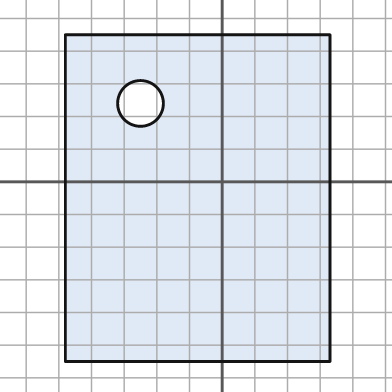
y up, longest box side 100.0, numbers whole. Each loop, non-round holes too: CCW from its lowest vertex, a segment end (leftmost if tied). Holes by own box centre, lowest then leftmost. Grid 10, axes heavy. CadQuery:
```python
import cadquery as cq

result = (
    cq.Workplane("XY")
    .moveTo(-48.0, -55.0)
    .lineTo(33.0, -55.0)
    .lineTo(33.0, 45.0)
    .lineTo(-48.0, 45.0)
    .close()
    .moveTo(-25.0, 24.0)
    .circle(7.0)
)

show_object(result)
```